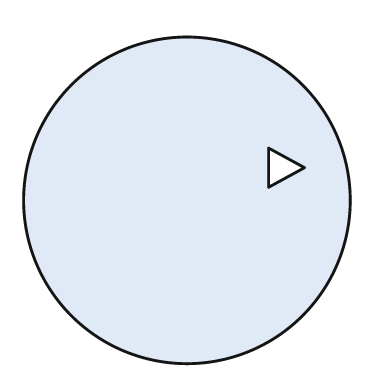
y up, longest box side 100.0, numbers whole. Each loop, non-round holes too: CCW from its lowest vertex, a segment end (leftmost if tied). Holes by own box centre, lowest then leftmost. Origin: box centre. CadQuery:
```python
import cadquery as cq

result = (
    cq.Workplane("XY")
    .moveTo(0.0, 0.0)
    .circle(50.0)
    .moveTo(25.0, 4.0)
    .lineTo(36.0, 10.0)
    .lineTo(25.0, 16.0)
    .close()
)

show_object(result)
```